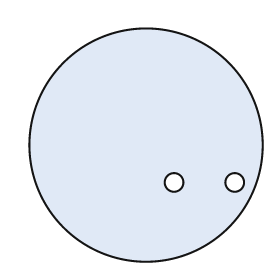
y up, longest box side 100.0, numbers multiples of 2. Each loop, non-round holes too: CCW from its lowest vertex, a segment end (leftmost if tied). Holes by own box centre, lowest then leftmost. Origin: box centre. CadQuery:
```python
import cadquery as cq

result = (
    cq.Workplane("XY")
    .moveTo(0.0, 0.0)
    .circle(50.0)
    .moveTo(12.0, -16.0)
    .circle(4.0)
    .moveTo(38.0, -16.0)
    .circle(4.0)
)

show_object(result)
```